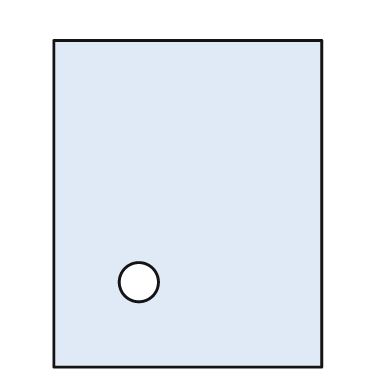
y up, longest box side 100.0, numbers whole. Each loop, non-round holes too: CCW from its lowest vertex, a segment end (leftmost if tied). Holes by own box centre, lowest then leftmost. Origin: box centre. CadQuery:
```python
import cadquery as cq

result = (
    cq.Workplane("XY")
    .moveTo(-41.0, -50.0)
    .lineTo(41.0, -50.0)
    .lineTo(41.0, 50.0)
    .lineTo(-41.0, 50.0)
    .close()
    .moveTo(-15.0, -24.0)
    .circle(6.0)
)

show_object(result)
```